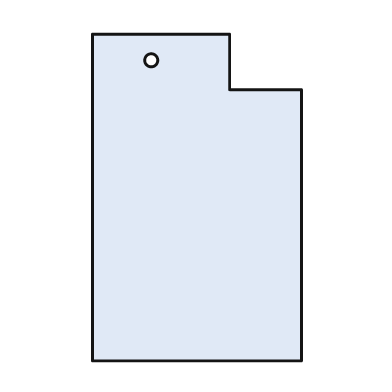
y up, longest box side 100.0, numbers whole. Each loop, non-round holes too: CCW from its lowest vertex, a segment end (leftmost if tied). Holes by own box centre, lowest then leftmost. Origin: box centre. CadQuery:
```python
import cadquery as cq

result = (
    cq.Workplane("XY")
    .moveTo(-32.0, -50.0)
    .lineTo(32.0, -50.0)
    .lineTo(32.0, 33.0)
    .lineTo(10.0, 33.0)
    .lineTo(10.0, 50.0)
    .lineTo(-32.0, 50.0)
    .close()
    .moveTo(-14.0, 42.0)
    .circle(2.0)
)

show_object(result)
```